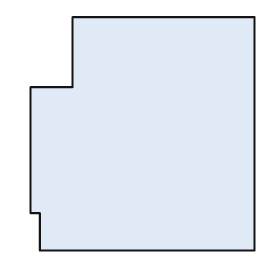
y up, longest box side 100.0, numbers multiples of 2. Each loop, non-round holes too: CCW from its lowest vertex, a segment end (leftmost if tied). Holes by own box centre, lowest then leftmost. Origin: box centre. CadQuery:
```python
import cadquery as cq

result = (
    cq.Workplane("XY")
    .moveTo(-44.0, -50.0)
    .lineTo(48.0, -50.0)
    .lineTo(48.0, 50.0)
    .lineTo(-30.0, 50.0)
    .lineTo(-30.0, 20.0)
    .lineTo(-48.0, 20.0)
    .lineTo(-48.0, -34.0)
    .lineTo(-44.0, -34.0)
    .close()
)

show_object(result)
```